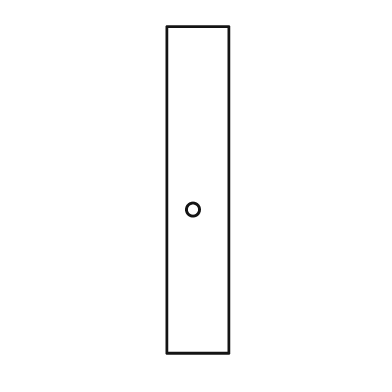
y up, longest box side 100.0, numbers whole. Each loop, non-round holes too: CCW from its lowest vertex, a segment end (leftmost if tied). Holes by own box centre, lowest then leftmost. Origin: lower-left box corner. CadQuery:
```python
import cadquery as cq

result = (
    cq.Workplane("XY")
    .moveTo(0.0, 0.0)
    .lineTo(19.0, 0.0)
    .lineTo(19.0, 100.0)
    .lineTo(0.0, 100.0)
    .close()
    .moveTo(8.0, 44.0)
    .circle(2.0)
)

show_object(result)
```